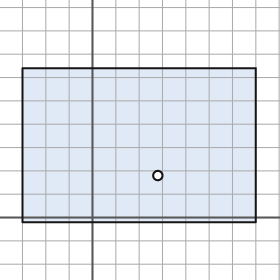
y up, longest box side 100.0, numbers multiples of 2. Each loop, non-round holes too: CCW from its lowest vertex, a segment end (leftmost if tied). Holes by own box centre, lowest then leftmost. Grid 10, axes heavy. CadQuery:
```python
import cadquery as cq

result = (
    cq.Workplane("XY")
    .moveTo(-30.0, -2.0)
    .lineTo(70.0, -2.0)
    .lineTo(70.0, 64.0)
    .lineTo(-30.0, 64.0)
    .close()
    .moveTo(28.0, 18.0)
    .circle(2.0)
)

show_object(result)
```